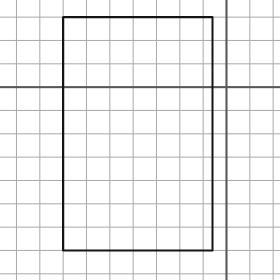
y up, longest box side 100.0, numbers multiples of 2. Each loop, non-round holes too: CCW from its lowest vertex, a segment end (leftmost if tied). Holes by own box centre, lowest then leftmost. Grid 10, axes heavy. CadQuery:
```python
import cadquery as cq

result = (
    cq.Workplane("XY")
    .moveTo(-70.0, -70.0)
    .lineTo(-6.0, -70.0)
    .lineTo(-6.0, 30.0)
    .lineTo(-70.0, 30.0)
    .close()
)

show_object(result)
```